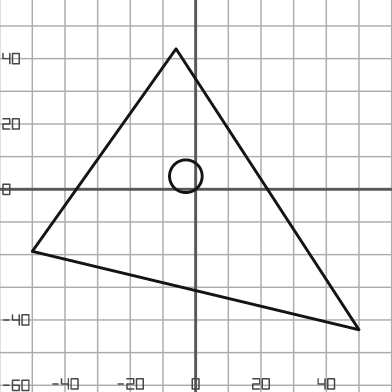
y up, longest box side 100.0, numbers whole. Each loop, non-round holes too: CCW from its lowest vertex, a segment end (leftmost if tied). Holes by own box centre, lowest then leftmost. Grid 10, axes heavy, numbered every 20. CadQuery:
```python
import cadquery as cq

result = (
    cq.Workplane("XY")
    .moveTo(50.0, -43.0)
    .lineTo(-6.0, 43.0)
    .lineTo(-50.0, -19.0)
    .close()
    .moveTo(-3.0, 4.0)
    .circle(5.0)
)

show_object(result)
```